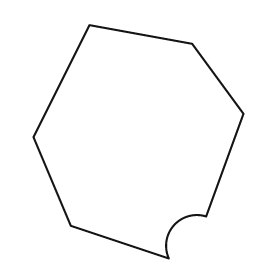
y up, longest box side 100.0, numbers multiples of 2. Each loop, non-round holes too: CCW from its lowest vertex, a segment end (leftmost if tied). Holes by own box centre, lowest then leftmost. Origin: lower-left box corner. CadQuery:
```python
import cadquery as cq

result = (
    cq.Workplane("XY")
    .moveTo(58.0, 0.0)
    .threePointArc((60.0, 14.0), (74.0, 18.0))
    .lineTo(90.0, 62.0)
    .lineTo(68.0, 92.0)
    .lineTo(24.0, 100.0)
    .lineTo(0.0, 52.0)
    .lineTo(16.0, 14.0)
    .close()
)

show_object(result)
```